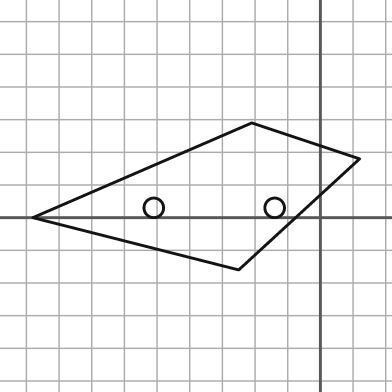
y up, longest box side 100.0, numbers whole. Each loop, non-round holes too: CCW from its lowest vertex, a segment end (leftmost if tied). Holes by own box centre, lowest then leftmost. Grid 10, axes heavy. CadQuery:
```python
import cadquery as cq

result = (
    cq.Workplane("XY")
    .moveTo(-25.0, -16.0)
    .lineTo(12.0, 18.0)
    .lineTo(-21.0, 29.0)
    .lineTo(-88.0, 0.0)
    .close()
    .moveTo(-51.0, 3.0)
    .circle(3.0)
    .moveTo(-14.0, 3.0)
    .circle(3.0)
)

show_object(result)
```